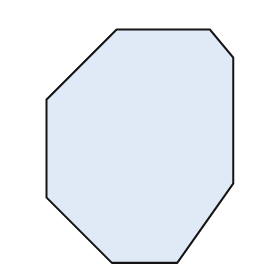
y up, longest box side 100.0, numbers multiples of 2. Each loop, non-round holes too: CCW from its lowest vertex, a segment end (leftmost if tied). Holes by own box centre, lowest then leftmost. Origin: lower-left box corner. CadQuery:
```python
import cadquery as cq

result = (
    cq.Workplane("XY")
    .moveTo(28.0, 0.0)
    .lineTo(56.0, 0.0)
    .lineTo(80.0, 34.0)
    .lineTo(80.0, 88.0)
    .lineTo(70.0, 100.0)
    .lineTo(30.0, 100.0)
    .lineTo(0.0, 70.0)
    .lineTo(0.0, 28.0)
    .close()
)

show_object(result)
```